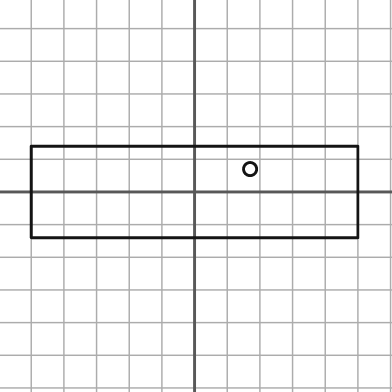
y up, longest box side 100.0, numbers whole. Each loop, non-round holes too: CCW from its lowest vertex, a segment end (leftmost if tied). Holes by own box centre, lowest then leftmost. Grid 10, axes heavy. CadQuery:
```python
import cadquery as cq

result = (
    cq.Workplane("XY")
    .moveTo(-50.0, -14.0)
    .lineTo(50.0, -14.0)
    .lineTo(50.0, 14.0)
    .lineTo(-50.0, 14.0)
    .close()
    .moveTo(17.0, 7.0)
    .circle(2.0)
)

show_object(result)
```